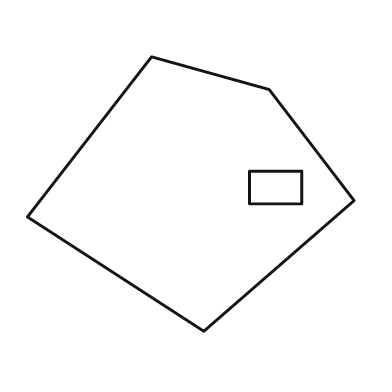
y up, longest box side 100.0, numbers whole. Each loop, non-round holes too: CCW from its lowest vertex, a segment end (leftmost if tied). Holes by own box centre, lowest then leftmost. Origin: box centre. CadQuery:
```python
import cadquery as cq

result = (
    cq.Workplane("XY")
    .moveTo(4.0, -42.0)
    .lineTo(50.0, -2.0)
    .lineTo(24.0, 32.0)
    .lineTo(-12.0, 42.0)
    .lineTo(-50.0, -7.0)
    .close()
    .moveTo(18.0, -3.0)
    .lineTo(34.0, -3.0)
    .lineTo(34.0, 7.0)
    .lineTo(18.0, 7.0)
    .close()
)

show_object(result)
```